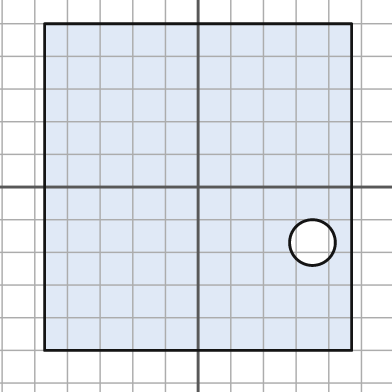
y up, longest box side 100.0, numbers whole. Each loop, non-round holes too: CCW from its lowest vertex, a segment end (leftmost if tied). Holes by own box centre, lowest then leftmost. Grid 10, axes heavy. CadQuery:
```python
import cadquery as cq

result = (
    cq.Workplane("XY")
    .moveTo(-47.0, -50.0)
    .lineTo(47.0, -50.0)
    .lineTo(47.0, 50.0)
    .lineTo(-47.0, 50.0)
    .close()
    .moveTo(35.0, -17.0)
    .circle(7.0)
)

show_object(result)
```